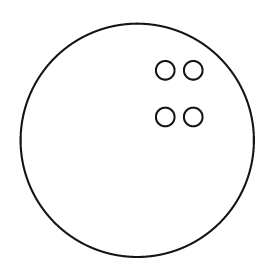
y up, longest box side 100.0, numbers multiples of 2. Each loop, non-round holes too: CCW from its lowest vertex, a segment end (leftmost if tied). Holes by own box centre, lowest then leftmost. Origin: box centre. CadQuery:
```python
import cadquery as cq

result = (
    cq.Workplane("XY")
    .moveTo(0.0, 0.0)
    .circle(50.0)
    .moveTo(12.0, 10.0)
    .circle(4.0)
    .moveTo(24.0, 10.0)
    .circle(4.0)
    .moveTo(12.0, 30.0)
    .circle(4.0)
    .moveTo(24.0, 30.0)
    .circle(4.0)
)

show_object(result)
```